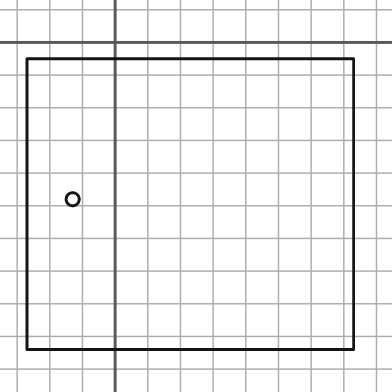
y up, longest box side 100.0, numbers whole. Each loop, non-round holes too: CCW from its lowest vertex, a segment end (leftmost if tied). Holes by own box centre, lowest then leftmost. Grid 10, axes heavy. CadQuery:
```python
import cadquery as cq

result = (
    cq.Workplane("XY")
    .moveTo(-27.0, -94.0)
    .lineTo(73.0, -94.0)
    .lineTo(73.0, -5.0)
    .lineTo(-27.0, -5.0)
    .close()
    .moveTo(-13.0, -48.0)
    .circle(2.0)
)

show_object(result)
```